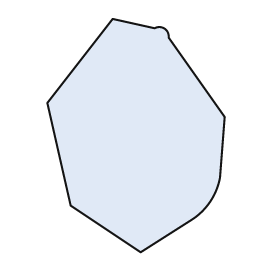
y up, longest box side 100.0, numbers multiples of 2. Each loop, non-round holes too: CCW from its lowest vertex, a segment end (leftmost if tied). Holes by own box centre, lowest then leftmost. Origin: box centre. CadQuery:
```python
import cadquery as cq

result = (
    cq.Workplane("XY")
    .moveTo(2.0, -50.0)
    .lineTo(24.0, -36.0)
    .threePointArc((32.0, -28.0), (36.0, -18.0))
    .lineTo(38.0, 8.0)
    .lineTo(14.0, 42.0)
    .threePointArc((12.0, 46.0), (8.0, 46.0))
    .lineTo(-10.0, 50.0)
    .lineTo(-38.0, 14.0)
    .lineTo(-28.0, -30.0)
    .close()
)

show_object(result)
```